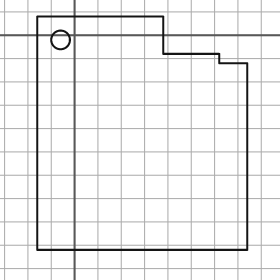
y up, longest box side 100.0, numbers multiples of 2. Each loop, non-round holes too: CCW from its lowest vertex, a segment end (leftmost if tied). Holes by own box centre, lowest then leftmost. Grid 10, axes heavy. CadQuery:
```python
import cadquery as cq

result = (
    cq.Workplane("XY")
    .moveTo(-16.0, -92.0)
    .lineTo(74.0, -92.0)
    .lineTo(74.0, -12.0)
    .lineTo(62.0, -12.0)
    .lineTo(62.0, -8.0)
    .lineTo(38.0, -8.0)
    .lineTo(38.0, 8.0)
    .lineTo(-16.0, 8.0)
    .close()
    .moveTo(-6.0, -2.0)
    .circle(4.0)
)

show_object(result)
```